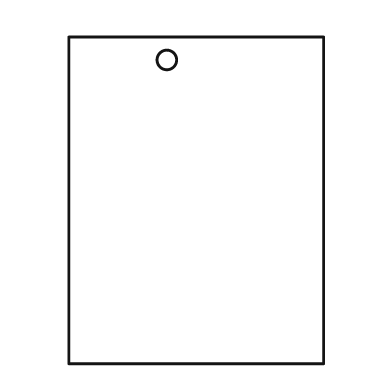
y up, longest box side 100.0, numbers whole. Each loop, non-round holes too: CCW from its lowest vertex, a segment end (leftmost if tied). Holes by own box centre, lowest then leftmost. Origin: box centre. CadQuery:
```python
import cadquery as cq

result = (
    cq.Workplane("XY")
    .moveTo(-39.0, -50.0)
    .lineTo(39.0, -50.0)
    .lineTo(39.0, 50.0)
    .lineTo(-39.0, 50.0)
    .close()
    .moveTo(-9.0, 43.0)
    .circle(3.0)
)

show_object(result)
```